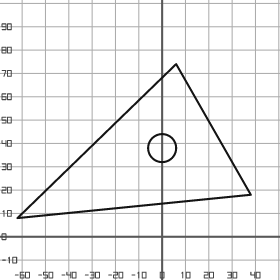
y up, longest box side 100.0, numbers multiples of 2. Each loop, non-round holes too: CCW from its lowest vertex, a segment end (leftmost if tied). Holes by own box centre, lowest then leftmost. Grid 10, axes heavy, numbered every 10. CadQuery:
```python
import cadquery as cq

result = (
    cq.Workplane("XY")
    .moveTo(-62.0, 8.0)
    .lineTo(38.0, 18.0)
    .lineTo(6.0, 74.0)
    .close()
    .moveTo(0.0, 38.0)
    .circle(6.0)
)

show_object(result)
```